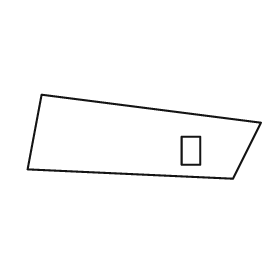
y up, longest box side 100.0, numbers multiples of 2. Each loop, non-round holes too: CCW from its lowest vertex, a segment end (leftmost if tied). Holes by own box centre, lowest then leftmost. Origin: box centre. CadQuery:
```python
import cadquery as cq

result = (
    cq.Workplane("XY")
    .moveTo(38.0, -18.0)
    .lineTo(50.0, 6.0)
    .lineTo(-44.0, 18.0)
    .lineTo(-50.0, -14.0)
    .close()
    .moveTo(16.0, -12.0)
    .lineTo(24.0, -12.0)
    .lineTo(24.0, 0.0)
    .lineTo(16.0, 0.0)
    .close()
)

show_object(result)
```